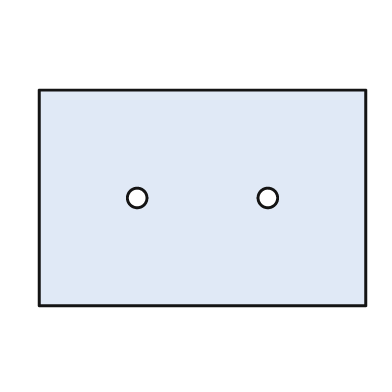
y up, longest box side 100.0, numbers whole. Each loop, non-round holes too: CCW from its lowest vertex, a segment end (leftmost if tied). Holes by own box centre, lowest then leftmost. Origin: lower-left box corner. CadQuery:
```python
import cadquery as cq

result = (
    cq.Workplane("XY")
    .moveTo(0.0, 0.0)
    .lineTo(100.0, 0.0)
    .lineTo(100.0, 66.0)
    .lineTo(0.0, 66.0)
    .close()
    .moveTo(30.0, 33.0)
    .circle(3.0)
    .moveTo(70.0, 33.0)
    .circle(3.0)
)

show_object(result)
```